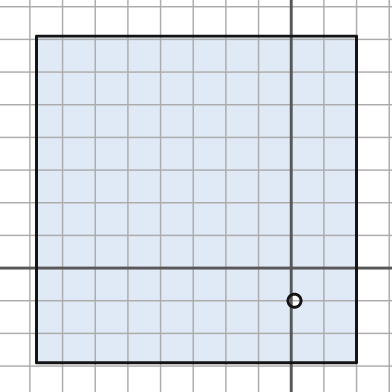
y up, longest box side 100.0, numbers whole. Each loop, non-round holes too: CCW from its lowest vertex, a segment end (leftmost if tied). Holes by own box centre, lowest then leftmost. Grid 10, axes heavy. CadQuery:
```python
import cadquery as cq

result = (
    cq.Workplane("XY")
    .moveTo(-78.0, -29.0)
    .lineTo(20.0, -29.0)
    .lineTo(20.0, 71.0)
    .lineTo(-78.0, 71.0)
    .close()
    .moveTo(1.0, -10.0)
    .circle(2.0)
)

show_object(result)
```